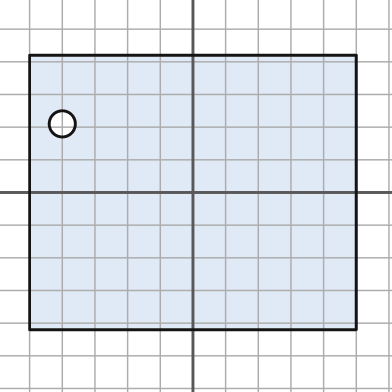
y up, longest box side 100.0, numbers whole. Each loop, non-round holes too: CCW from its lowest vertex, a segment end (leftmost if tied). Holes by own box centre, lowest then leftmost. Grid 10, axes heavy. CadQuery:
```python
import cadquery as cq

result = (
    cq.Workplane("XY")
    .moveTo(-50.0, -42.0)
    .lineTo(50.0, -42.0)
    .lineTo(50.0, 42.0)
    .lineTo(-50.0, 42.0)
    .close()
    .moveTo(-40.0, 21.0)
    .circle(4.0)
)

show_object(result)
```